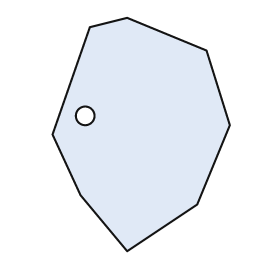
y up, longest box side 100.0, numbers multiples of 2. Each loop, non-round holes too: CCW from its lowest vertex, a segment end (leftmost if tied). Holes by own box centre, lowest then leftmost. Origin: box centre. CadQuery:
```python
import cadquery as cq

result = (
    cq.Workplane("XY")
    .moveTo(-6.0, -50.0)
    .lineTo(24.0, -30.0)
    .lineTo(38.0, 4.0)
    .lineTo(28.0, 36.0)
    .lineTo(-6.0, 50.0)
    .lineTo(-22.0, 46.0)
    .lineTo(-38.0, 0.0)
    .lineTo(-26.0, -26.0)
    .close()
    .moveTo(-24.0, 8.0)
    .circle(4.0)
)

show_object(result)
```